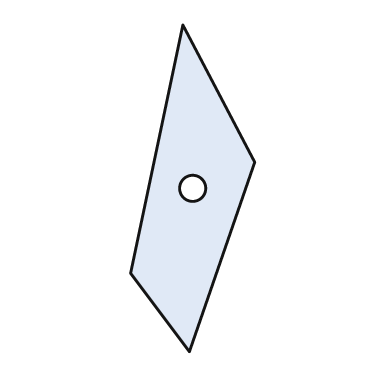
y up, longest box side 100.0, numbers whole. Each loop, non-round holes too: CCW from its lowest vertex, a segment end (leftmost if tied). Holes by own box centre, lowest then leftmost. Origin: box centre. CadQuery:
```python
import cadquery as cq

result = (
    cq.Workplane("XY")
    .moveTo(-1.0, -50.0)
    .lineTo(19.0, 8.0)
    .lineTo(-3.0, 50.0)
    .lineTo(-19.0, -26.0)
    .close()
    .moveTo(0.0, 0.0)
    .circle(4.0)
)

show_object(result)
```